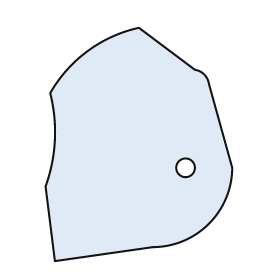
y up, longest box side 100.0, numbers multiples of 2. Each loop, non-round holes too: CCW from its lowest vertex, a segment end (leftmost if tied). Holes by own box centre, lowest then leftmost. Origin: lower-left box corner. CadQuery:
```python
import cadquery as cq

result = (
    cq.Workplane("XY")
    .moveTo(4.0, 0.0)
    .lineTo(46.0, 6.0)
    .threePointArc((70.0, 16.0), (80.0, 40.0))
    .lineTo(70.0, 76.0)
    .threePointArc((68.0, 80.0), (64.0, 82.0))
    .lineTo(40.0, 100.0)
    .threePointArc((18.0, 90.0), (2.0, 72.0))
    .threePointArc((4.0, 52.0), (0.0, 32.0))
    .close()
    .moveTo(60.0, 40.0)
    .circle(4.0)
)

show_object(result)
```